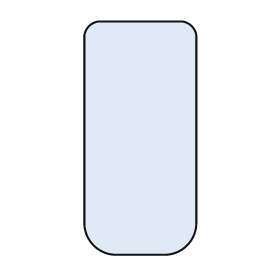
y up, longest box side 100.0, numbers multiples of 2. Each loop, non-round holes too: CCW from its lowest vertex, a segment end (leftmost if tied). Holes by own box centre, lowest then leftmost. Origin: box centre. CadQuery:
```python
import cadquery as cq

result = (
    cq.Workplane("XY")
    .moveTo(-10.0, -50.0)
    .lineTo(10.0, -50.0)
    .threePointArc((20.0, -46.0), (24.0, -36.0))
    .lineTo(24.0, 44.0)
    .threePointArc((22.0, 48.0), (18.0, 50.0))
    .lineTo(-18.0, 50.0)
    .threePointArc((-22.0, 48.0), (-24.0, 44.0))
    .lineTo(-24.0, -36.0)
    .threePointArc((-20.0, -46.0), (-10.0, -50.0))
    .close()
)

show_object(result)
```